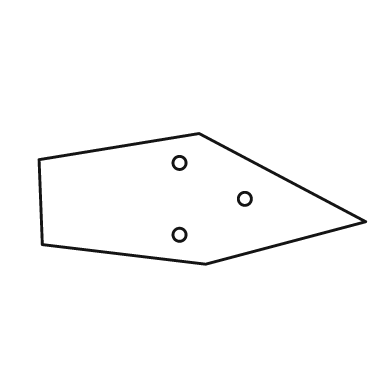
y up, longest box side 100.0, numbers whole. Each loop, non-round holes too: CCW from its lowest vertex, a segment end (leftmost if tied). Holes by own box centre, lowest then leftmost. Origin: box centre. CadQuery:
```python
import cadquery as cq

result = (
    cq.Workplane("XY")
    .moveTo(1.0, -20.0)
    .lineTo(50.0, -7.0)
    .lineTo(-1.0, 20.0)
    .lineTo(-50.0, 12.0)
    .lineTo(-49.0, -14.0)
    .close()
    .moveTo(-7.0, -11.0)
    .circle(2.0)
    .moveTo(13.0, 0.0)
    .circle(2.0)
    .moveTo(-7.0, 11.0)
    .circle(2.0)
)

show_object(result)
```